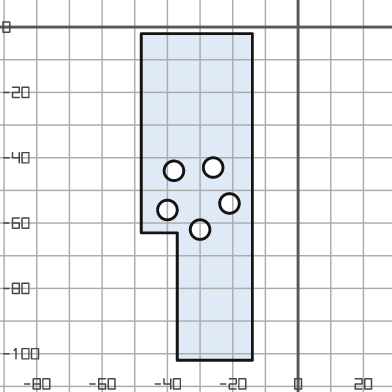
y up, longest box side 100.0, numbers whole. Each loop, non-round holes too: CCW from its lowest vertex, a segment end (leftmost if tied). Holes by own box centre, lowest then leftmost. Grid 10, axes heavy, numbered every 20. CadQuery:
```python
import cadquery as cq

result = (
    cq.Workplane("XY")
    .moveTo(-37.0, -102.0)
    .lineTo(-14.0, -102.0)
    .lineTo(-14.0, -2.0)
    .lineTo(-48.0, -2.0)
    .lineTo(-48.0, -63.0)
    .lineTo(-37.0, -63.0)
    .close()
    .moveTo(-30.0, -62.0)
    .circle(3.0)
    .moveTo(-40.0, -56.0)
    .circle(3.0)
    .moveTo(-21.0, -54.0)
    .circle(3.0)
    .moveTo(-38.0, -44.0)
    .circle(3.0)
    .moveTo(-26.0, -43.0)
    .circle(3.0)
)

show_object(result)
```